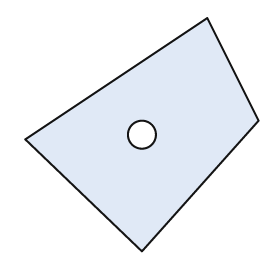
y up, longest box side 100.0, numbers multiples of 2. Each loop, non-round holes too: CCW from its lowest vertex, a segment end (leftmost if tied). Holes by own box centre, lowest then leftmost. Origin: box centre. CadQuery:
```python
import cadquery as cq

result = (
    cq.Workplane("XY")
    .moveTo(0.0, -50.0)
    .lineTo(50.0, 6.0)
    .lineTo(28.0, 50.0)
    .lineTo(-50.0, -2.0)
    .close()
    .moveTo(0.0, 0.0)
    .circle(6.0)
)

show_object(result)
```